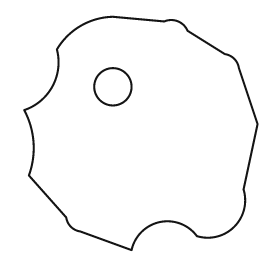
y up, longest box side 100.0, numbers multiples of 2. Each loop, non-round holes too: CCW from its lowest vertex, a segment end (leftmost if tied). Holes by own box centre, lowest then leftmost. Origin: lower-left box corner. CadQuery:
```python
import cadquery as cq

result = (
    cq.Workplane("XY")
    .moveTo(46.0, 0.0)
    .threePointArc((58.0, 12.0), (74.0, 6.0))
    .threePointArc((90.0, 10.0), (94.0, 26.0))
    .lineTo(100.0, 54.0)
    .lineTo(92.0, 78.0)
    .threePointArc((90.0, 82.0), (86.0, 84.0))
    .lineTo(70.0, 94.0)
    .threePointArc((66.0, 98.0), (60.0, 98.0))
    .lineTo(38.0, 100.0)
    .threePointArc((24.0, 96.0), (14.0, 86.0))
    .threePointArc((12.0, 70.0), (0.0, 60.0))
    .threePointArc((4.0, 46.0), (2.0, 32.0))
    .lineTo(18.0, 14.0)
    .threePointArc((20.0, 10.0), (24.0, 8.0))
    .close()
    .moveTo(38.0, 70.0)
    .circle(8.0)
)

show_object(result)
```